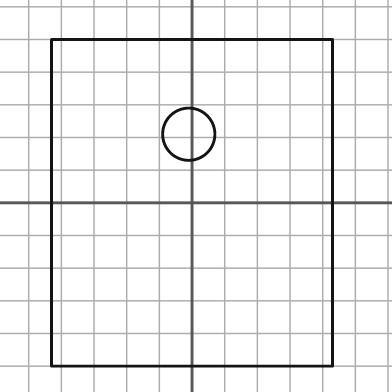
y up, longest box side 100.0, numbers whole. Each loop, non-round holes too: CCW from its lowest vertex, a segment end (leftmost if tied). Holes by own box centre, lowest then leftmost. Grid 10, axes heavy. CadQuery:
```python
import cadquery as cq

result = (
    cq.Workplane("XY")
    .moveTo(-43.0, -50.0)
    .lineTo(43.0, -50.0)
    .lineTo(43.0, 50.0)
    .lineTo(-43.0, 50.0)
    .close()
    .moveTo(-1.0, 21.0)
    .circle(8.0)
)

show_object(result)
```